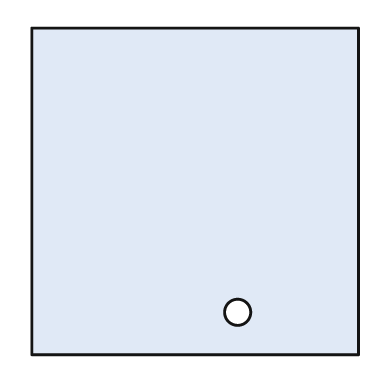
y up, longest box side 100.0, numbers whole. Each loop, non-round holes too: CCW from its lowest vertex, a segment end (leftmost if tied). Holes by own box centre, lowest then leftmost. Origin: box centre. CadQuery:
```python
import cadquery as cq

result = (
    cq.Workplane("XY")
    .moveTo(-50.0, -50.0)
    .lineTo(50.0, -50.0)
    .lineTo(50.0, 50.0)
    .lineTo(-50.0, 50.0)
    .close()
    .moveTo(13.0, -37.0)
    .circle(4.0)
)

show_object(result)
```